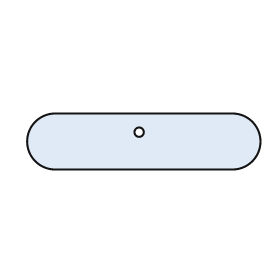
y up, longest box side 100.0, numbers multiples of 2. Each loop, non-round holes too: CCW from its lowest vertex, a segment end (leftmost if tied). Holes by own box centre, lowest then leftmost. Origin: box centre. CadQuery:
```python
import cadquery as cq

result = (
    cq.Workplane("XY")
    .moveTo(-38.0, -12.0)
    .lineTo(38.0, -12.0)
    .threePointArc((50.0, 0.0), (38.0, 12.0))
    .lineTo(-38.0, 12.0)
    .threePointArc((-50.0, 0.0), (-38.0, -12.0))
    .close()
    .moveTo(-2.0, 4.0)
    .circle(2.0)
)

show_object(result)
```